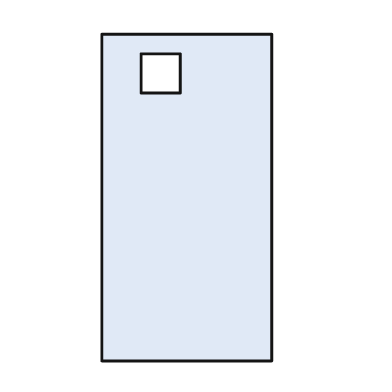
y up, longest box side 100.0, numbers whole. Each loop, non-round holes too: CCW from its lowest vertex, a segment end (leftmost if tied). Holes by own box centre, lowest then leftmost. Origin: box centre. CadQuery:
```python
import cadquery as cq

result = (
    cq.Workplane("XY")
    .moveTo(-26.0, -50.0)
    .lineTo(26.0, -50.0)
    .lineTo(26.0, 50.0)
    .lineTo(-26.0, 50.0)
    .close()
    .moveTo(-14.0, 32.0)
    .lineTo(-2.0, 32.0)
    .lineTo(-2.0, 44.0)
    .lineTo(-14.0, 44.0)
    .close()
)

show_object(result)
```